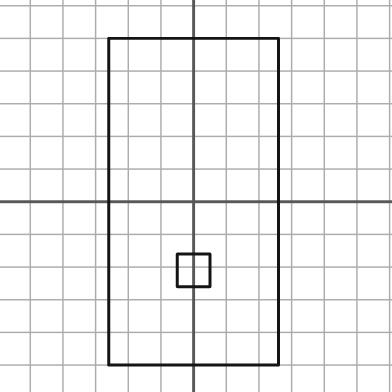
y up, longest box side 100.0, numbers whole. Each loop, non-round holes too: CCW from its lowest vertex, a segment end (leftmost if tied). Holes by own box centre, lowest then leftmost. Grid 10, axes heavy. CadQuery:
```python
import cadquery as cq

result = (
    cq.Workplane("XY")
    .moveTo(-26.0, -50.0)
    .lineTo(26.0, -50.0)
    .lineTo(26.0, 50.0)
    .lineTo(-26.0, 50.0)
    .close()
    .moveTo(-5.0, -26.0)
    .lineTo(5.0, -26.0)
    .lineTo(5.0, -16.0)
    .lineTo(-5.0, -16.0)
    .close()
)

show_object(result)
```